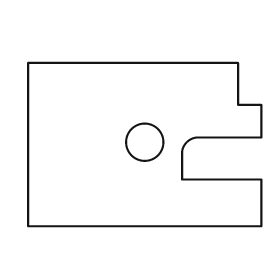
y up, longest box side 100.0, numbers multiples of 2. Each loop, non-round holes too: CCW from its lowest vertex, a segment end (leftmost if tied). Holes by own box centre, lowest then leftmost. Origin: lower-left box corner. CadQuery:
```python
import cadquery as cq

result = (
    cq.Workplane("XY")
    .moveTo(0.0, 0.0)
    .lineTo(100.0, 0.0)
    .lineTo(100.0, 20.0)
    .lineTo(66.0, 20.0)
    .lineTo(66.0, 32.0)
    .threePointArc((68.0, 36.0), (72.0, 38.0))
    .lineTo(100.0, 38.0)
    .lineTo(100.0, 52.0)
    .lineTo(90.0, 52.0)
    .lineTo(90.0, 70.0)
    .lineTo(0.0, 70.0)
    .close()
    .moveTo(50.0, 36.0)
    .circle(8.0)
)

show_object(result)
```